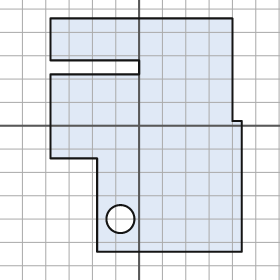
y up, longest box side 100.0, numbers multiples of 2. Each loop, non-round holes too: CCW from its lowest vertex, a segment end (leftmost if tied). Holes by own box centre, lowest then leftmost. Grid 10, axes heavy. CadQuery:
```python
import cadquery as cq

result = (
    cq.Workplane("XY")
    .moveTo(-18.0, -54.0)
    .lineTo(44.0, -54.0)
    .lineTo(44.0, 2.0)
    .lineTo(40.0, 2.0)
    .lineTo(40.0, 46.0)
    .lineTo(-38.0, 46.0)
    .lineTo(-38.0, 28.0)
    .lineTo(0.0, 28.0)
    .lineTo(0.0, 22.0)
    .lineTo(-38.0, 22.0)
    .lineTo(-38.0, -14.0)
    .lineTo(-18.0, -14.0)
    .close()
    .moveTo(-8.0, -40.0)
    .circle(6.0)
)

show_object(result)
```